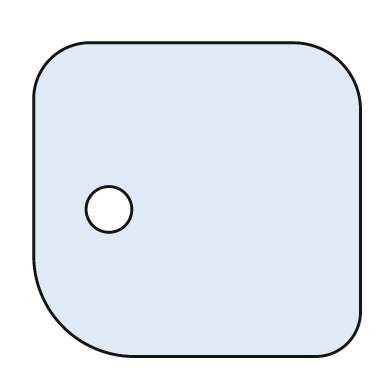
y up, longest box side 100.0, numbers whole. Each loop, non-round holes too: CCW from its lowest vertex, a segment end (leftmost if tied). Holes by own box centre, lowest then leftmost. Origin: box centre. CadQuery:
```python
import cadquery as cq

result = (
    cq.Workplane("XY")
    .moveTo(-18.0, -48.0)
    .lineTo(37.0, -48.0)
    .threePointArc((46.0, -44.0), (50.0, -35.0))
    .lineTo(50.0, 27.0)
    .threePointArc((44.0, 42.0), (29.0, 48.0))
    .lineTo(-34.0, 48.0)
    .threePointArc((-45.0, 43.0), (-50.0, 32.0))
    .lineTo(-50.0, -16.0)
    .threePointArc((-41.0, -39.0), (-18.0, -48.0))
    .close()
    .moveTo(-27.0, -3.0)
    .circle(7.0)
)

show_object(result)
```